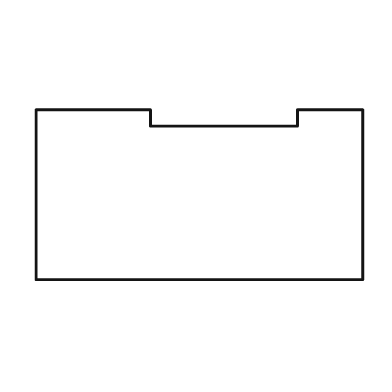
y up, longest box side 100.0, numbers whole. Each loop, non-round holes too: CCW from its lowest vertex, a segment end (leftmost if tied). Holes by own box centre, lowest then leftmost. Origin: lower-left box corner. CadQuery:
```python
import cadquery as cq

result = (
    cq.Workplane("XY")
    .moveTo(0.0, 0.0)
    .lineTo(100.0, 0.0)
    .lineTo(100.0, 52.0)
    .lineTo(80.0, 52.0)
    .lineTo(80.0, 47.0)
    .lineTo(35.0, 47.0)
    .lineTo(35.0, 52.0)
    .lineTo(0.0, 52.0)
    .close()
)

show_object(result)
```